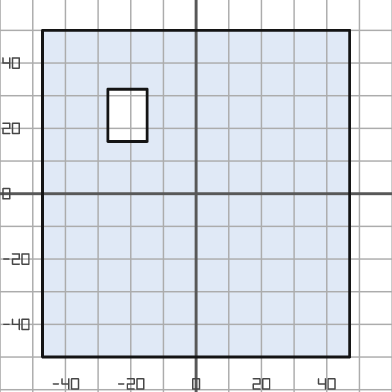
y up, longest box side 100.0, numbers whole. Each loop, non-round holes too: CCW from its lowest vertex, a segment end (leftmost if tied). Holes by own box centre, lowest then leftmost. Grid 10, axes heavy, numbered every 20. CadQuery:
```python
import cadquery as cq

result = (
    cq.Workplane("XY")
    .moveTo(-47.0, -50.0)
    .lineTo(47.0, -50.0)
    .lineTo(47.0, 50.0)
    .lineTo(-47.0, 50.0)
    .close()
    .moveTo(-27.0, 16.0)
    .lineTo(-15.0, 16.0)
    .lineTo(-15.0, 32.0)
    .lineTo(-27.0, 32.0)
    .close()
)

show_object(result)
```